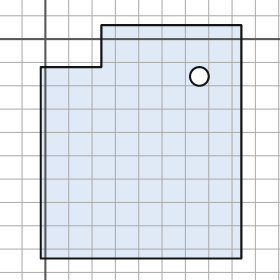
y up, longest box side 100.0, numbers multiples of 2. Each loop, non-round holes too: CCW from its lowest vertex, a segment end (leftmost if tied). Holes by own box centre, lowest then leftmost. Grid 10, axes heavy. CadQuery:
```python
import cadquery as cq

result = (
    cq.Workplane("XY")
    .moveTo(-2.0, -94.0)
    .lineTo(84.0, -94.0)
    .lineTo(84.0, 6.0)
    .lineTo(24.0, 6.0)
    .lineTo(24.0, -12.0)
    .lineTo(-2.0, -12.0)
    .close()
    .moveTo(66.0, -16.0)
    .circle(4.0)
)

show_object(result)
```